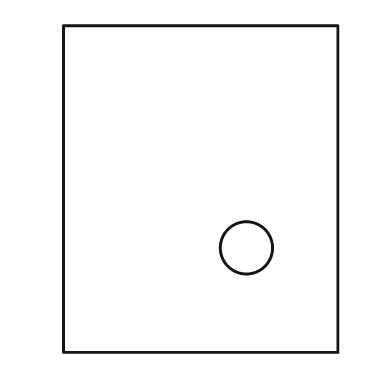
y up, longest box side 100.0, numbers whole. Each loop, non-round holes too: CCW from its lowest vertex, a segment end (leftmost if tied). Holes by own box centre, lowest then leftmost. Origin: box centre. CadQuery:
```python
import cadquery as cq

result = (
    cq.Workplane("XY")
    .moveTo(-42.0, -50.0)
    .lineTo(42.0, -50.0)
    .lineTo(42.0, 50.0)
    .lineTo(-42.0, 50.0)
    .close()
    .moveTo(14.0, -18.0)
    .circle(8.0)
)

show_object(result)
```